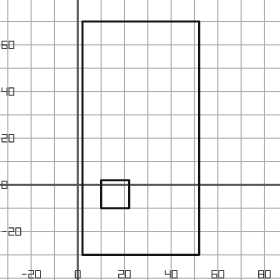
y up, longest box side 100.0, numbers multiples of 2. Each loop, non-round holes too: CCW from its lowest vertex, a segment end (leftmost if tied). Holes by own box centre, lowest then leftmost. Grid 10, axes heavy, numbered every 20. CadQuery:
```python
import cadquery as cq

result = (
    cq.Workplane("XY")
    .moveTo(2.0, -30.0)
    .lineTo(52.0, -30.0)
    .lineTo(52.0, 70.0)
    .lineTo(2.0, 70.0)
    .close()
    .moveTo(10.0, -10.0)
    .lineTo(22.0, -10.0)
    .lineTo(22.0, 2.0)
    .lineTo(10.0, 2.0)
    .close()
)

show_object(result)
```